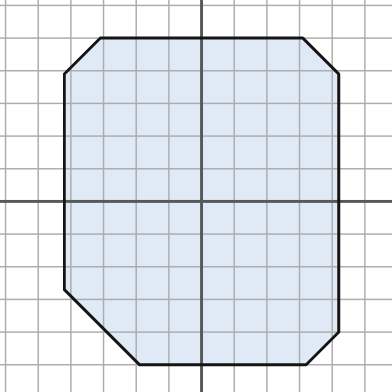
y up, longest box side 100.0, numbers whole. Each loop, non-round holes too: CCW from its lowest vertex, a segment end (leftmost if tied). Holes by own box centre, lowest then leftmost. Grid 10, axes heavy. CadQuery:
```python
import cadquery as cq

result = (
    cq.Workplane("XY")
    .moveTo(-19.0, -50.0)
    .lineTo(32.0, -50.0)
    .lineTo(42.0, -40.0)
    .lineTo(42.0, 39.0)
    .lineTo(31.0, 50.0)
    .lineTo(-31.0, 50.0)
    .lineTo(-42.0, 39.0)
    .lineTo(-42.0, -27.0)
    .close()
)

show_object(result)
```